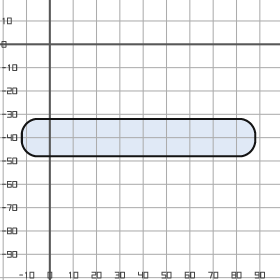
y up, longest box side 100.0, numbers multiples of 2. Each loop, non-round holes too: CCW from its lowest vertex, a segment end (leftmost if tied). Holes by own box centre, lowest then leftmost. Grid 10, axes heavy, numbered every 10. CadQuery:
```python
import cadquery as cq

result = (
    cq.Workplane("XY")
    .moveTo(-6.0, -48.0)
    .lineTo(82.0, -48.0)
    .threePointArc((86.0, -46.0), (88.0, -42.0))
    .lineTo(88.0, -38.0)
    .threePointArc((86.0, -34.0), (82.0, -32.0))
    .lineTo(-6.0, -32.0)
    .threePointArc((-10.0, -34.0), (-12.0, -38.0))
    .lineTo(-12.0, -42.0)
    .threePointArc((-10.0, -46.0), (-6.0, -48.0))
    .close()
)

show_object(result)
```